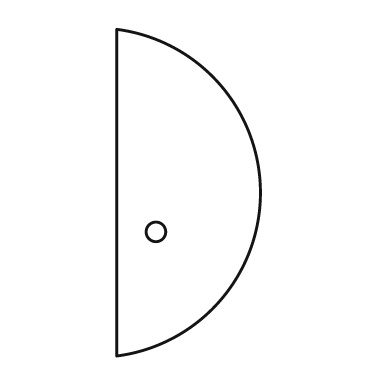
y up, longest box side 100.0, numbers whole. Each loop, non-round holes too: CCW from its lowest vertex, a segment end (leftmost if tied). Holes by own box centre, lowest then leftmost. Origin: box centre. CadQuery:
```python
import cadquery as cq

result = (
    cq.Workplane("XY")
    .moveTo(-22.0, -50.0)
    .threePointArc((22.0, 0.0), (-22.0, 50.0))
    .close()
    .moveTo(-10.0, -12.0)
    .circle(3.0)
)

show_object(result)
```